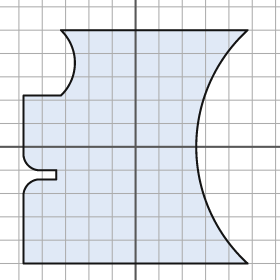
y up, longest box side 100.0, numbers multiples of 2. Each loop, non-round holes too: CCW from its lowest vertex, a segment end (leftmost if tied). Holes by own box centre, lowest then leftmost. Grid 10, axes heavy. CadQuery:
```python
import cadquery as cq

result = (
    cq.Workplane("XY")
    .moveTo(-48.0, -50.0)
    .lineTo(48.0, -50.0)
    .threePointArc((26.0, 0.0), (48.0, 50.0))
    .lineTo(-32.0, 50.0)
    .threePointArc((-26.0, 36.0), (-32.0, 22.0))
    .lineTo(-48.0, 22.0)
    .lineTo(-48.0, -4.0)
    .threePointArc((-46.0, -8.0), (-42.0, -10.0))
    .lineTo(-34.0, -10.0)
    .lineTo(-34.0, -14.0)
    .lineTo(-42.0, -14.0)
    .threePointArc((-46.0, -16.0), (-48.0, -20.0))
    .close()
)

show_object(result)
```